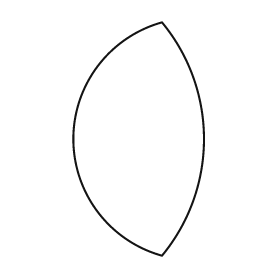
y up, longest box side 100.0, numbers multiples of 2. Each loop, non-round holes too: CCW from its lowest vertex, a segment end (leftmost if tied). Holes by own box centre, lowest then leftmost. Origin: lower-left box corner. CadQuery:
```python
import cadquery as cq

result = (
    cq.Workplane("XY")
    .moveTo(38.0, 0.0)
    .threePointArc((56.0, 50.0), (38.0, 100.0))
    .threePointArc((0.0, 50.0), (38.0, 0.0))
    .close()
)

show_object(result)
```